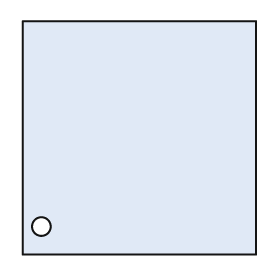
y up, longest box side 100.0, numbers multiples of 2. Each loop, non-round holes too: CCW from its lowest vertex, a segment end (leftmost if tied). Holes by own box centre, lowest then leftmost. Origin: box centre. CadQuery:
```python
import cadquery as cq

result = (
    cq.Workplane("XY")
    .moveTo(-50.0, -50.0)
    .lineTo(50.0, -50.0)
    .lineTo(50.0, 50.0)
    .lineTo(-50.0, 50.0)
    .close()
    .moveTo(-42.0, -38.0)
    .circle(4.0)
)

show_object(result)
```